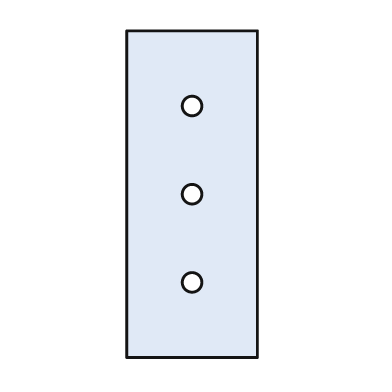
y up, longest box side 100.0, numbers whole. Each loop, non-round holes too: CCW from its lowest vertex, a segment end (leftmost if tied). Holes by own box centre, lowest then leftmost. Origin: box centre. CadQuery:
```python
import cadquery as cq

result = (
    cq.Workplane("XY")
    .moveTo(-20.0, -50.0)
    .lineTo(20.0, -50.0)
    .lineTo(20.0, 50.0)
    .lineTo(-20.0, 50.0)
    .close()
    .moveTo(0.0, -27.0)
    .circle(3.0)
    .moveTo(0.0, 0.0)
    .circle(3.0)
    .moveTo(0.0, 27.0)
    .circle(3.0)
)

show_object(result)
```